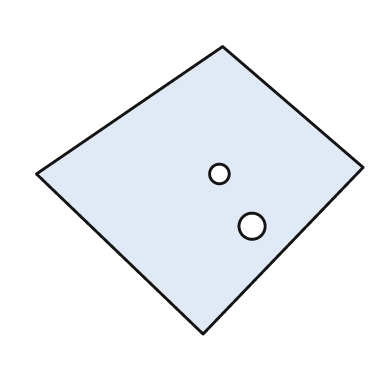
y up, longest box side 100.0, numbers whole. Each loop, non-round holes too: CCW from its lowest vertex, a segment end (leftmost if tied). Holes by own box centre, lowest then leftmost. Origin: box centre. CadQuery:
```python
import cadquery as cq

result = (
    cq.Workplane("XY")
    .moveTo(1.0, -44.0)
    .lineTo(50.0, 7.0)
    .lineTo(7.0, 44.0)
    .lineTo(-50.0, 5.0)
    .close()
    .moveTo(16.0, -11.0)
    .circle(4.0)
    .moveTo(6.0, 5.0)
    .circle(3.0)
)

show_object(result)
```